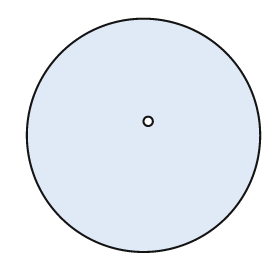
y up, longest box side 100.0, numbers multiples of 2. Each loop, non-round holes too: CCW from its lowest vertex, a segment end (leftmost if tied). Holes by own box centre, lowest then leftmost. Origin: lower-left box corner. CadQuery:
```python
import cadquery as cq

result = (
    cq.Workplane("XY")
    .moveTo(50.0, 50.0)
    .circle(50.0)
    .moveTo(52.0, 56.0)
    .circle(2.0)
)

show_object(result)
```